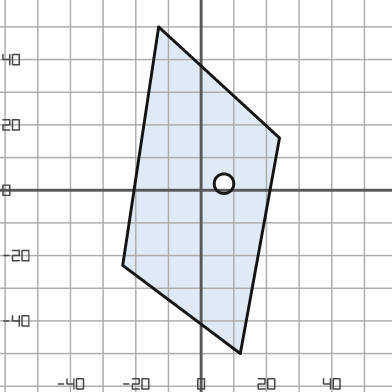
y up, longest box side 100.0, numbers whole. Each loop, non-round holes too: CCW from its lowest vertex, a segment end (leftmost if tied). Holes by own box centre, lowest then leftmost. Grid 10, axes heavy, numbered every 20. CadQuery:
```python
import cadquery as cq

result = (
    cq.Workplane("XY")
    .moveTo(12.0, -50.0)
    .lineTo(24.0, 16.0)
    .lineTo(-13.0, 50.0)
    .lineTo(-24.0, -23.0)
    .close()
    .moveTo(7.0, 2.0)
    .circle(3.0)
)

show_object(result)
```